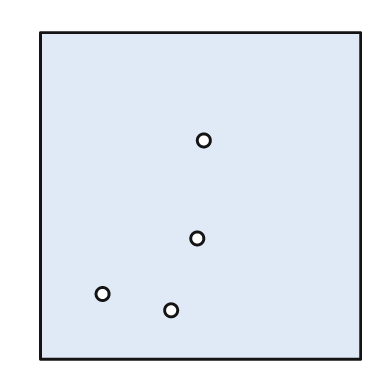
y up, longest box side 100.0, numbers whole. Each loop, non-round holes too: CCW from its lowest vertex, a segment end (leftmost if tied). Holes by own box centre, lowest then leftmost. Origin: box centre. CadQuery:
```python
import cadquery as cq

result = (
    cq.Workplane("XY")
    .moveTo(-49.0, -50.0)
    .lineTo(49.0, -50.0)
    .lineTo(49.0, 50.0)
    .lineTo(-49.0, 50.0)
    .close()
    .moveTo(-9.0, -35.0)
    .circle(2.0)
    .moveTo(-30.0, -30.0)
    .circle(2.0)
    .moveTo(-1.0, -13.0)
    .circle(2.0)
    .moveTo(1.0, 17.0)
    .circle(2.0)
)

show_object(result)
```